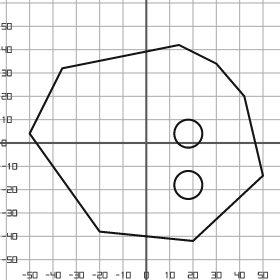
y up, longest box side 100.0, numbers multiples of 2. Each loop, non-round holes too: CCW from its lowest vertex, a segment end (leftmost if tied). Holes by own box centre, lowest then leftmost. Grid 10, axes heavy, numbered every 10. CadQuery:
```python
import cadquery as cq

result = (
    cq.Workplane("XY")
    .moveTo(20.0, -42.0)
    .lineTo(50.0, -14.0)
    .lineTo(42.0, 20.0)
    .lineTo(30.0, 34.0)
    .lineTo(14.0, 42.0)
    .lineTo(-36.0, 32.0)
    .lineTo(-50.0, 4.0)
    .lineTo(-20.0, -38.0)
    .close()
    .moveTo(18.0, -18.0)
    .circle(6.0)
    .moveTo(18.0, 4.0)
    .circle(6.0)
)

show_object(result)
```